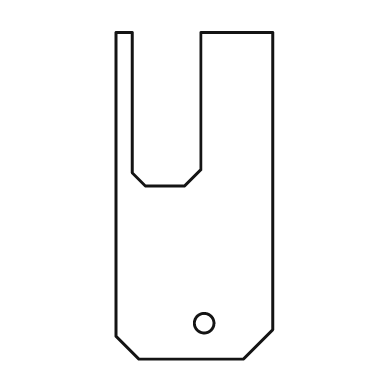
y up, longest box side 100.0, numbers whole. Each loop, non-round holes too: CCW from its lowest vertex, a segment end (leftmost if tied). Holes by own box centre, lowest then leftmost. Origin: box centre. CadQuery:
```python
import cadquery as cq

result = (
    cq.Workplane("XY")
    .moveTo(-17.0, -50.0)
    .lineTo(15.0, -50.0)
    .lineTo(24.0, -41.0)
    .lineTo(24.0, 50.0)
    .lineTo(2.0, 50.0)
    .lineTo(2.0, 8.0)
    .lineTo(-3.0, 3.0)
    .lineTo(-15.0, 3.0)
    .lineTo(-19.0, 7.0)
    .lineTo(-19.0, 50.0)
    .lineTo(-24.0, 50.0)
    .lineTo(-24.0, -43.0)
    .close()
    .moveTo(3.0, -39.0)
    .circle(3.0)
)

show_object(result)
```